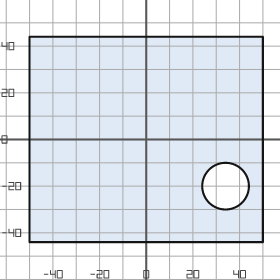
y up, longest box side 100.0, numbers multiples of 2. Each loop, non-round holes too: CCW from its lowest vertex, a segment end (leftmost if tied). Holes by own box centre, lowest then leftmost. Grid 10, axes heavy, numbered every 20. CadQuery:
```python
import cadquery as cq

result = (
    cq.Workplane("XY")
    .moveTo(-50.0, -44.0)
    .lineTo(50.0, -44.0)
    .lineTo(50.0, 44.0)
    .lineTo(-50.0, 44.0)
    .close()
    .moveTo(34.0, -20.0)
    .circle(10.0)
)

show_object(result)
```